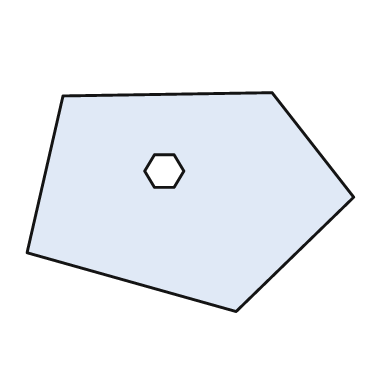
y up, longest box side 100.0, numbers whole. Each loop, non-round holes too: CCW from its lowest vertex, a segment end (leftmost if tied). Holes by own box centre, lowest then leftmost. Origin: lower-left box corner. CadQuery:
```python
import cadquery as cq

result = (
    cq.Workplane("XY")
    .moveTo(64.0, 0.0)
    .lineTo(100.0, 35.0)
    .lineTo(75.0, 67.0)
    .lineTo(11.0, 66.0)
    .lineTo(0.0, 18.0)
    .close()
    .moveTo(39.0, 38.0)
    .lineTo(45.0, 38.0)
    .lineTo(48.0, 43.0)
    .lineTo(45.0, 48.0)
    .lineTo(39.0, 48.0)
    .lineTo(36.0, 43.0)
    .close()
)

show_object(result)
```